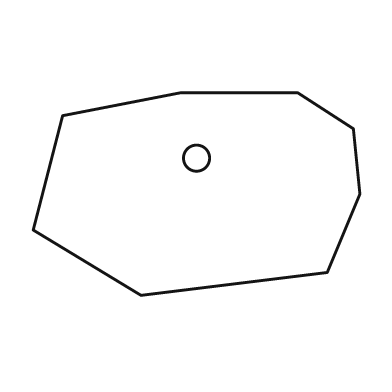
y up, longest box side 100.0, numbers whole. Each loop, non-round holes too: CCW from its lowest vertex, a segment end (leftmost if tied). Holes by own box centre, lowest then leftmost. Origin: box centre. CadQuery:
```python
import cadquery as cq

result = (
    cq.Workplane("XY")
    .moveTo(-17.0, -31.0)
    .lineTo(40.0, -24.0)
    .lineTo(50.0, 0.0)
    .lineTo(48.0, 20.0)
    .lineTo(31.0, 31.0)
    .lineTo(-5.0, 31.0)
    .lineTo(-41.0, 24.0)
    .lineTo(-50.0, -11.0)
    .close()
    .moveTo(0.0, 11.0)
    .circle(4.0)
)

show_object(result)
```